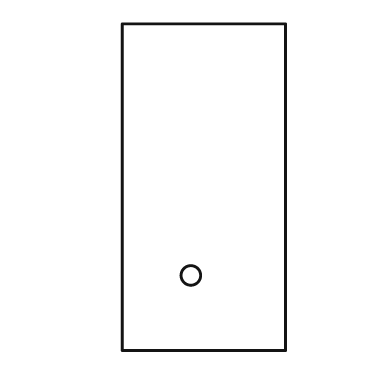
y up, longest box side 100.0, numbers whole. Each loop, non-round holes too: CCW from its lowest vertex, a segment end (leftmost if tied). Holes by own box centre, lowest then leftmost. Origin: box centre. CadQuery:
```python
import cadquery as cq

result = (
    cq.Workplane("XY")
    .moveTo(-25.0, -50.0)
    .lineTo(25.0, -50.0)
    .lineTo(25.0, 50.0)
    .lineTo(-25.0, 50.0)
    .close()
    .moveTo(-4.0, -27.0)
    .circle(3.0)
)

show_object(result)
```